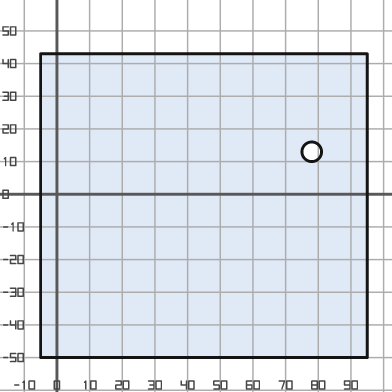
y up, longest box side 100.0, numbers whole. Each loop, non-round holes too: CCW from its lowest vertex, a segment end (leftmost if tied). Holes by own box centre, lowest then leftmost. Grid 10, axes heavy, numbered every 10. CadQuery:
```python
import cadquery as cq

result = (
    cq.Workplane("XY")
    .moveTo(-5.0, -50.0)
    .lineTo(95.0, -50.0)
    .lineTo(95.0, 43.0)
    .lineTo(-5.0, 43.0)
    .close()
    .moveTo(78.0, 13.0)
    .circle(3.0)
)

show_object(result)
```